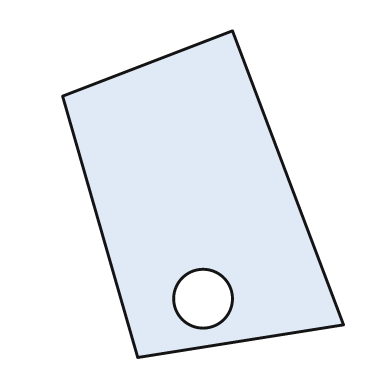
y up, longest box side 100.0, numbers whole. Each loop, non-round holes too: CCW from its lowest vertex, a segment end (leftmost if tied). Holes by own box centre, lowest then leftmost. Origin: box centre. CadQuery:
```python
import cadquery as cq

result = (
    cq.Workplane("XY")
    .moveTo(-20.0, -50.0)
    .lineTo(43.0, -40.0)
    .lineTo(9.0, 50.0)
    .lineTo(-43.0, 30.0)
    .close()
    .moveTo(0.0, -32.0)
    .circle(9.0)
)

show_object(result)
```